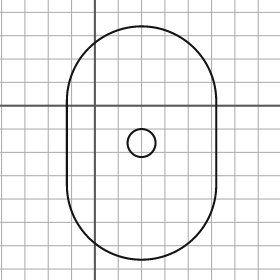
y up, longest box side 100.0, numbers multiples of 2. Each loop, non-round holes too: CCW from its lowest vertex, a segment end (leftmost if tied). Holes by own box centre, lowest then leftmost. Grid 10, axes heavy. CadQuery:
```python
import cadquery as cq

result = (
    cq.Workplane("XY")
    .moveTo(-12.0, -34.0)
    .threePointArc((20.0, -66.0), (52.0, -34.0))
    .lineTo(52.0, 2.0)
    .threePointArc((20.0, 34.0), (-12.0, 2.0))
    .close()
    .moveTo(20.0, -16.0)
    .circle(6.0)
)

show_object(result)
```